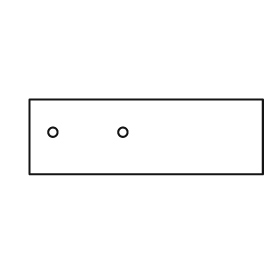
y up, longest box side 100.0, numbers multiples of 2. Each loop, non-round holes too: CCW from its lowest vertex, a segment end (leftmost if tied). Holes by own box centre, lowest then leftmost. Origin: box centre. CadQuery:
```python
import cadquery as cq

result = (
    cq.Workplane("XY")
    .moveTo(-50.0, -16.0)
    .lineTo(50.0, -16.0)
    .lineTo(50.0, 16.0)
    .lineTo(-50.0, 16.0)
    .close()
    .moveTo(-40.0, 2.0)
    .circle(2.0)
    .moveTo(-10.0, 2.0)
    .circle(2.0)
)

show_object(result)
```